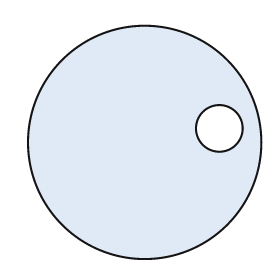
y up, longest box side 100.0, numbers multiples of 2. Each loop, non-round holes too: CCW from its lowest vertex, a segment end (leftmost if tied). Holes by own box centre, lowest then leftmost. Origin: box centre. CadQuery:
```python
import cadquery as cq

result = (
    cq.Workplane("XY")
    .moveTo(0.0, 0.0)
    .circle(50.0)
    .moveTo(32.0, 6.0)
    .circle(10.0)
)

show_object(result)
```